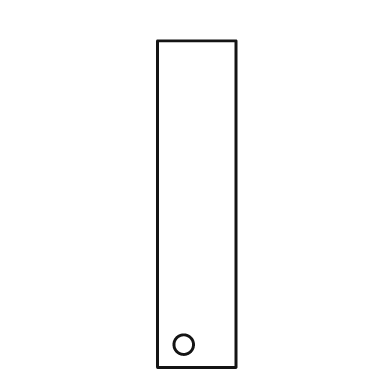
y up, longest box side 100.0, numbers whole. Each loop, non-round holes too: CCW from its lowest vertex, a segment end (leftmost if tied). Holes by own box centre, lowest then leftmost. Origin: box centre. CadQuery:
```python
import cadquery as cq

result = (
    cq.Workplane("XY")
    .moveTo(-12.0, -50.0)
    .lineTo(12.0, -50.0)
    .lineTo(12.0, 50.0)
    .lineTo(-12.0, 50.0)
    .close()
    .moveTo(-4.0, -43.0)
    .circle(3.0)
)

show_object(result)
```